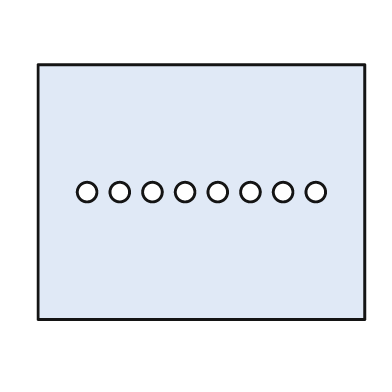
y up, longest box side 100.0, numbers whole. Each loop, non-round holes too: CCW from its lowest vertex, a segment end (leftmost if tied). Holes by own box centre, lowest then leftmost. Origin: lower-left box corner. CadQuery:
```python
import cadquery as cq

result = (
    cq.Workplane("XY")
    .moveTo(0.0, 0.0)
    .lineTo(100.0, 0.0)
    .lineTo(100.0, 78.0)
    .lineTo(0.0, 78.0)
    .close()
    .moveTo(15.0, 39.0)
    .circle(3.0)
    .moveTo(25.0, 39.0)
    .circle(3.0)
    .moveTo(35.0, 39.0)
    .circle(3.0)
    .moveTo(45.0, 39.0)
    .circle(3.0)
    .moveTo(55.0, 39.0)
    .circle(3.0)
    .moveTo(65.0, 39.0)
    .circle(3.0)
    .moveTo(75.0, 39.0)
    .circle(3.0)
    .moveTo(85.0, 39.0)
    .circle(3.0)
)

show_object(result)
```